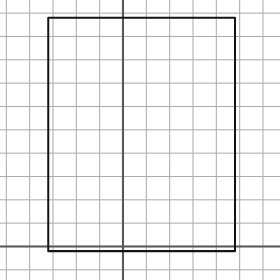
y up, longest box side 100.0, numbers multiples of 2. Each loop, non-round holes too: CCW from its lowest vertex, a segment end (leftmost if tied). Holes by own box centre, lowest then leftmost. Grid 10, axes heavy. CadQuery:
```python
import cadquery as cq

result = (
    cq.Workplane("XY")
    .moveTo(-32.0, -2.0)
    .lineTo(48.0, -2.0)
    .lineTo(48.0, 98.0)
    .lineTo(-32.0, 98.0)
    .close()
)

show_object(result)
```